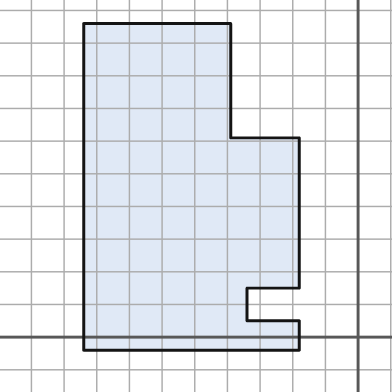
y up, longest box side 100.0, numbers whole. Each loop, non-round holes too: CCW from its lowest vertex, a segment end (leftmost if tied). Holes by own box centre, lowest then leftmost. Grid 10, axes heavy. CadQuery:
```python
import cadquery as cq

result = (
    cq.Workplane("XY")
    .moveTo(-84.0, -4.0)
    .lineTo(-18.0, -4.0)
    .lineTo(-18.0, 5.0)
    .lineTo(-34.0, 5.0)
    .lineTo(-34.0, 15.0)
    .lineTo(-18.0, 15.0)
    .lineTo(-18.0, 61.0)
    .lineTo(-39.0, 61.0)
    .lineTo(-39.0, 96.0)
    .lineTo(-84.0, 96.0)
    .close()
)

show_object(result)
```